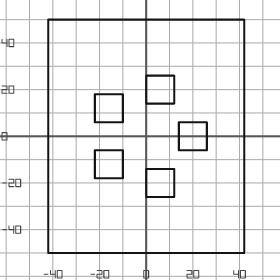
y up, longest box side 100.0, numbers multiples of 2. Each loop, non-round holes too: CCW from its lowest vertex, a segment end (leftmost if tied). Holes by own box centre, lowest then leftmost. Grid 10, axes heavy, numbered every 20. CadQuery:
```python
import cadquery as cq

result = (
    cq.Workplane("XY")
    .moveTo(-42.0, -50.0)
    .lineTo(42.0, -50.0)
    .lineTo(42.0, 50.0)
    .lineTo(-42.0, 50.0)
    .close()
    .moveTo(0.0, -26.0)
    .lineTo(12.0, -26.0)
    .lineTo(12.0, -14.0)
    .lineTo(0.0, -14.0)
    .close()
    .moveTo(-22.0, -18.0)
    .lineTo(-10.0, -18.0)
    .lineTo(-10.0, -6.0)
    .lineTo(-22.0, -6.0)
    .close()
    .moveTo(14.0, -6.0)
    .lineTo(26.0, -6.0)
    .lineTo(26.0, 6.0)
    .lineTo(14.0, 6.0)
    .close()
    .moveTo(-22.0, 6.0)
    .lineTo(-10.0, 6.0)
    .lineTo(-10.0, 18.0)
    .lineTo(-22.0, 18.0)
    .close()
    .moveTo(0.0, 14.0)
    .lineTo(12.0, 14.0)
    .lineTo(12.0, 26.0)
    .lineTo(0.0, 26.0)
    .close()
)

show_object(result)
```